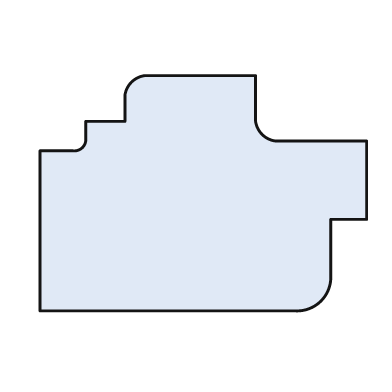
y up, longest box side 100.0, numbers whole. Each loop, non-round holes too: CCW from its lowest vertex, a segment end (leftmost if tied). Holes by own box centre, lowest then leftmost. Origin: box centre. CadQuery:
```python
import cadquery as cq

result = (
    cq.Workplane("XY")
    .moveTo(-50.0, -36.0)
    .lineTo(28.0, -36.0)
    .threePointArc((36.0, -33.0), (39.0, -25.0))
    .lineTo(39.0, -8.0)
    .lineTo(50.0, -8.0)
    .lineTo(50.0, 16.0)
    .lineTo(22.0, 16.0)
    .threePointArc((18.0, 18.0), (16.0, 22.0))
    .lineTo(16.0, 36.0)
    .lineTo(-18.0, 36.0)
    .threePointArc((-22.0, 34.0), (-24.0, 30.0))
    .lineTo(-24.0, 22.0)
    .lineTo(-36.0, 22.0)
    .lineTo(-36.0, 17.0)
    .threePointArc((-37.0, 14.0), (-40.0, 13.0))
    .lineTo(-50.0, 13.0)
    .close()
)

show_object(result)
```